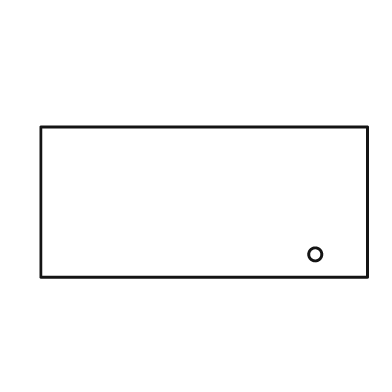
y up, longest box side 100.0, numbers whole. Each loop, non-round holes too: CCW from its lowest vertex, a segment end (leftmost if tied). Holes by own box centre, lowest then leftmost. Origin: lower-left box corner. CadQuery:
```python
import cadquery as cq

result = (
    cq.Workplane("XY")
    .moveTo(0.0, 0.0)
    .lineTo(100.0, 0.0)
    .lineTo(100.0, 46.0)
    .lineTo(0.0, 46.0)
    .close()
    .moveTo(84.0, 7.0)
    .circle(2.0)
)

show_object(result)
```